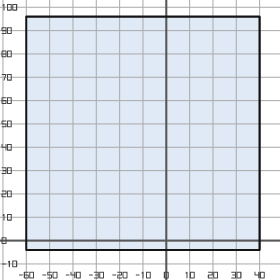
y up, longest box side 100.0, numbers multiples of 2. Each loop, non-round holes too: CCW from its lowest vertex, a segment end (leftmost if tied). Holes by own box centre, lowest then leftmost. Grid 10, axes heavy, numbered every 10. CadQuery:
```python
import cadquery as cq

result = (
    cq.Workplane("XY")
    .moveTo(-60.0, -4.0)
    .lineTo(40.0, -4.0)
    .lineTo(40.0, 96.0)
    .lineTo(-60.0, 96.0)
    .close()
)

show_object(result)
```